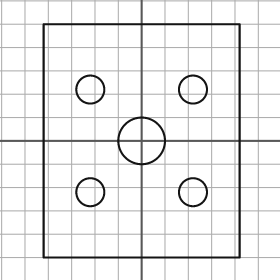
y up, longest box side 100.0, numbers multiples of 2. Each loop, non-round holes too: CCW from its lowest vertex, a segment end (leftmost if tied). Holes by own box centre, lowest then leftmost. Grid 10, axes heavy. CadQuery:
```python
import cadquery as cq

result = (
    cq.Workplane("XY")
    .moveTo(-42.0, -50.0)
    .lineTo(42.0, -50.0)
    .lineTo(42.0, 50.0)
    .lineTo(-42.0, 50.0)
    .close()
    .moveTo(-22.0, -22.0)
    .circle(6.0)
    .moveTo(22.0, -22.0)
    .circle(6.0)
    .moveTo(0.0, 0.0)
    .circle(10.0)
    .moveTo(-22.0, 22.0)
    .circle(6.0)
    .moveTo(22.0, 22.0)
    .circle(6.0)
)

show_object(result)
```